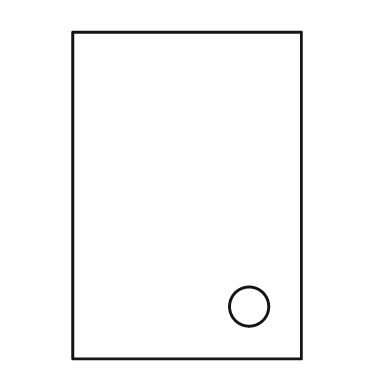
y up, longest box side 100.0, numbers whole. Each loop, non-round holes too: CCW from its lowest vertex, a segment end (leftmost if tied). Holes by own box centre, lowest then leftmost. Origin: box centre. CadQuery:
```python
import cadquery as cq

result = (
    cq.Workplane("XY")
    .moveTo(-35.0, -50.0)
    .lineTo(35.0, -50.0)
    .lineTo(35.0, 50.0)
    .lineTo(-35.0, 50.0)
    .close()
    .moveTo(19.0, -34.0)
    .circle(6.0)
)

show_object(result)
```